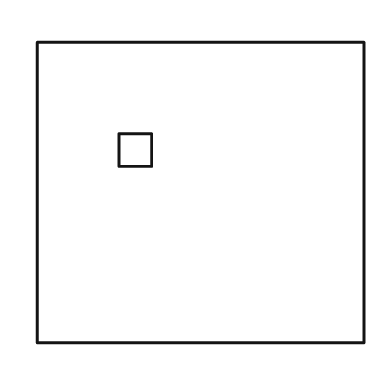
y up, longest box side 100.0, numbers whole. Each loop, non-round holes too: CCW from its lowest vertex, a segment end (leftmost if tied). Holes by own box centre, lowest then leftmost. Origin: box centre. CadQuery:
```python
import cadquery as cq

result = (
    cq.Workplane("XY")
    .moveTo(-50.0, -46.0)
    .lineTo(50.0, -46.0)
    .lineTo(50.0, 46.0)
    .lineTo(-50.0, 46.0)
    .close()
    .moveTo(-25.0, 8.0)
    .lineTo(-15.0, 8.0)
    .lineTo(-15.0, 18.0)
    .lineTo(-25.0, 18.0)
    .close()
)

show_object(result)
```